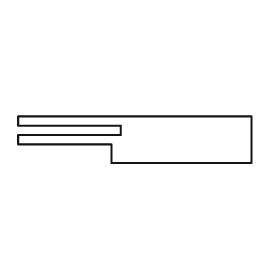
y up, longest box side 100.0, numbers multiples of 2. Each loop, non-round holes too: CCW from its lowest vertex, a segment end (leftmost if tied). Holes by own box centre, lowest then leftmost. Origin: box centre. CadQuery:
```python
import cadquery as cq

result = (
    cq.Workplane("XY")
    .moveTo(-10.0, -10.0)
    .lineTo(50.0, -10.0)
    .lineTo(50.0, 10.0)
    .lineTo(-50.0, 10.0)
    .lineTo(-50.0, 6.0)
    .lineTo(-6.0, 6.0)
    .lineTo(-6.0, 2.0)
    .lineTo(-50.0, 2.0)
    .lineTo(-50.0, -2.0)
    .lineTo(-10.0, -2.0)
    .close()
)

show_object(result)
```